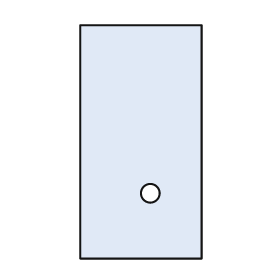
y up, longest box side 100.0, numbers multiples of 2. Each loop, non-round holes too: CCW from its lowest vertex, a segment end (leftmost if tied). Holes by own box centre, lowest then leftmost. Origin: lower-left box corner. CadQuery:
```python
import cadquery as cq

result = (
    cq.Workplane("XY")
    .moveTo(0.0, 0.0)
    .lineTo(52.0, 0.0)
    .lineTo(52.0, 100.0)
    .lineTo(0.0, 100.0)
    .close()
    .moveTo(30.0, 28.0)
    .circle(4.0)
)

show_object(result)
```